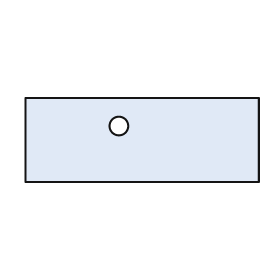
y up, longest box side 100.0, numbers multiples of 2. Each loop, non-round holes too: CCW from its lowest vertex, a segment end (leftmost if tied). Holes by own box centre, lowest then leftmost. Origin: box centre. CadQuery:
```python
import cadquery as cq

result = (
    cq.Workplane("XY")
    .moveTo(-50.0, -18.0)
    .lineTo(50.0, -18.0)
    .lineTo(50.0, 18.0)
    .lineTo(-50.0, 18.0)
    .close()
    .moveTo(-10.0, 6.0)
    .circle(4.0)
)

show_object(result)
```